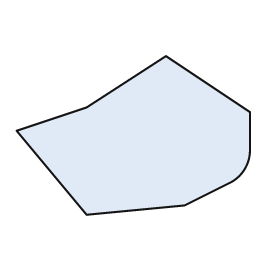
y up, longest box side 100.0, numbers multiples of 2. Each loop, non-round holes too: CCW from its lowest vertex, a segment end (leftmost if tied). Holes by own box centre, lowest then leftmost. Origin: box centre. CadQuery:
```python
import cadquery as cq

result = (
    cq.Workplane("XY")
    .moveTo(-20.0, -34.0)
    .lineTo(22.0, -30.0)
    .lineTo(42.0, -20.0)
    .threePointArc((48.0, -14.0), (50.0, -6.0))
    .lineTo(50.0, 10.0)
    .lineTo(14.0, 34.0)
    .lineTo(-20.0, 12.0)
    .lineTo(-50.0, 2.0)
    .close()
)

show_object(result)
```